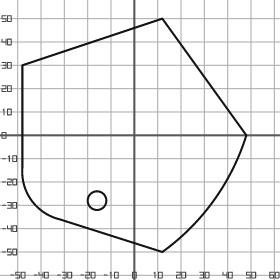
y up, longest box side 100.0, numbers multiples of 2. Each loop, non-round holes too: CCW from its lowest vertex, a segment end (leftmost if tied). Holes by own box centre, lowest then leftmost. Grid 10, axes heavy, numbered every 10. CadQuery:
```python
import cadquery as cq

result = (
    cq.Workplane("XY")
    .moveTo(12.0, -50.0)
    .threePointArc((34.0, -28.0), (48.0, 0.0))
    .lineTo(12.0, 50.0)
    .lineTo(-48.0, 30.0)
    .lineTo(-48.0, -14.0)
    .threePointArc((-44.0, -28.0), (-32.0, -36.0))
    .close()
    .moveTo(-16.0, -28.0)
    .circle(4.0)
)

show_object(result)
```